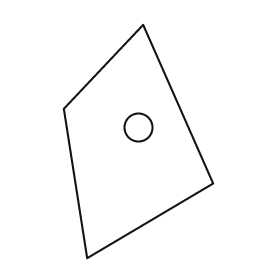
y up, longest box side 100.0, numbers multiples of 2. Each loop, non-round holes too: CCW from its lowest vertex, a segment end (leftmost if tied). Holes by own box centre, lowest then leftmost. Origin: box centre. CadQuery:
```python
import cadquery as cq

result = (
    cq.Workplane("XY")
    .moveTo(-22.0, -50.0)
    .lineTo(32.0, -18.0)
    .lineTo(2.0, 50.0)
    .lineTo(-32.0, 14.0)
    .close()
    .moveTo(0.0, 6.0)
    .circle(6.0)
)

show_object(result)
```